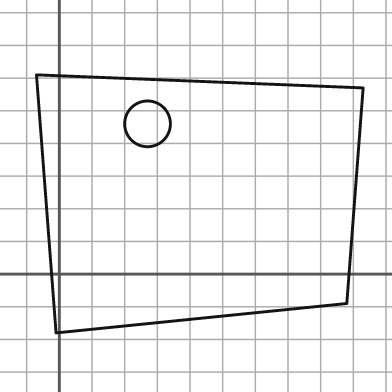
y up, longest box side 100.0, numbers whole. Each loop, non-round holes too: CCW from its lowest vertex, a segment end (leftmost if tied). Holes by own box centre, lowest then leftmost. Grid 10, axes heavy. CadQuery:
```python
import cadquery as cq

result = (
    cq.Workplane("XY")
    .moveTo(-1.0, -18.0)
    .lineTo(88.0, -9.0)
    .lineTo(93.0, 57.0)
    .lineTo(-7.0, 61.0)
    .close()
    .moveTo(27.0, 46.0)
    .circle(7.0)
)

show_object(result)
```